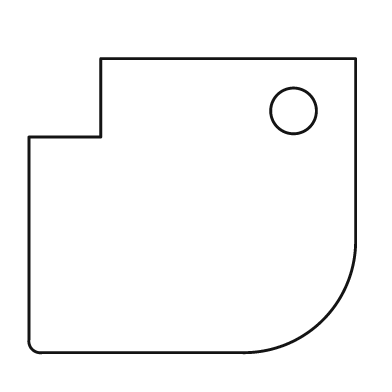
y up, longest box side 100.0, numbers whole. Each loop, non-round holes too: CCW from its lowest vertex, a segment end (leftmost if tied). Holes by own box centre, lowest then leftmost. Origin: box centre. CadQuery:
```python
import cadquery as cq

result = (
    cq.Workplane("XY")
    .moveTo(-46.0, -45.0)
    .lineTo(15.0, -45.0)
    .threePointArc((40.0, -35.0), (50.0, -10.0))
    .lineTo(50.0, 45.0)
    .lineTo(-28.0, 45.0)
    .lineTo(-28.0, 21.0)
    .lineTo(-50.0, 21.0)
    .lineTo(-50.0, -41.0)
    .threePointArc((-49.0, -44.0), (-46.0, -45.0))
    .close()
    .moveTo(31.0, 29.0)
    .circle(7.0)
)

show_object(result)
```